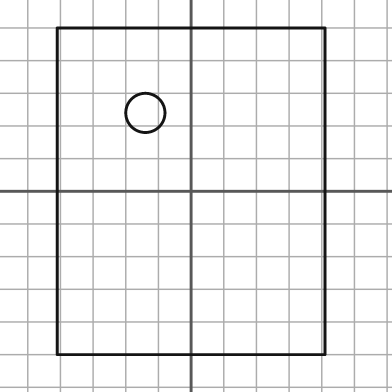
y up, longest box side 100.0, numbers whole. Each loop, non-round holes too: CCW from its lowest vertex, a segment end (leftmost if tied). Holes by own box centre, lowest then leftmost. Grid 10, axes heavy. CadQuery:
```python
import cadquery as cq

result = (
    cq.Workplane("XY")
    .moveTo(-41.0, -50.0)
    .lineTo(41.0, -50.0)
    .lineTo(41.0, 50.0)
    .lineTo(-41.0, 50.0)
    .close()
    .moveTo(-14.0, 24.0)
    .circle(6.0)
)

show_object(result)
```